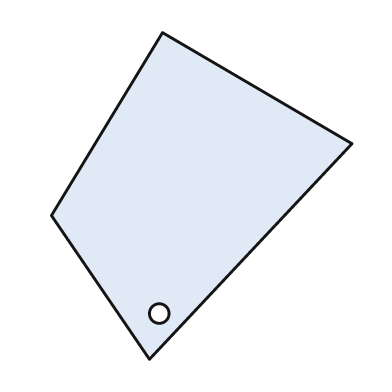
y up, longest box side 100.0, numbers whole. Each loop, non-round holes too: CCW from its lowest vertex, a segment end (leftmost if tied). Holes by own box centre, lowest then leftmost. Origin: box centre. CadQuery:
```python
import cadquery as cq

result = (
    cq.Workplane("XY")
    .moveTo(-16.0, -50.0)
    .lineTo(46.0, 16.0)
    .lineTo(-12.0, 50.0)
    .lineTo(-46.0, -6.0)
    .close()
    .moveTo(-13.0, -36.0)
    .circle(3.0)
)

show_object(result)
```